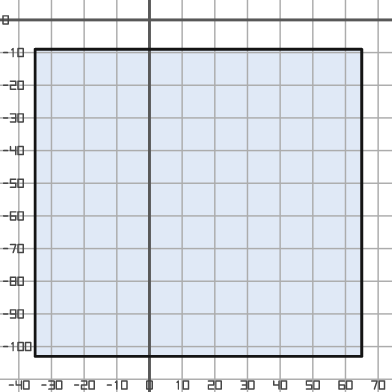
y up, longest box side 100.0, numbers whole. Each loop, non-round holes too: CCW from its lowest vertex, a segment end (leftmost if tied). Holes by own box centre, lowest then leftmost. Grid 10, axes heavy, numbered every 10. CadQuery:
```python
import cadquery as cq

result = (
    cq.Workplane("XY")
    .moveTo(-35.0, -103.0)
    .lineTo(65.0, -103.0)
    .lineTo(65.0, -9.0)
    .lineTo(-35.0, -9.0)
    .close()
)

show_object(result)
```